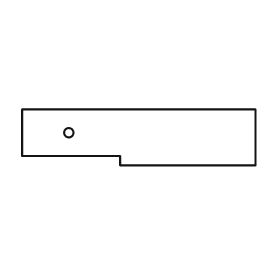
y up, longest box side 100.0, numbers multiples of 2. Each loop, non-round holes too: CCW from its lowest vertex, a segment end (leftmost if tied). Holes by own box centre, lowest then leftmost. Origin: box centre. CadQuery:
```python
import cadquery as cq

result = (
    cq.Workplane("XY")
    .moveTo(-8.0, -12.0)
    .lineTo(50.0, -12.0)
    .lineTo(50.0, 12.0)
    .lineTo(-50.0, 12.0)
    .lineTo(-50.0, -8.0)
    .lineTo(-8.0, -8.0)
    .close()
    .moveTo(-30.0, 2.0)
    .circle(2.0)
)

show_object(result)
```